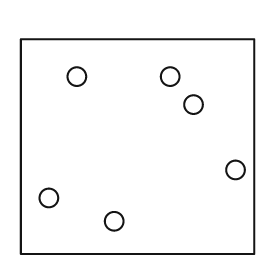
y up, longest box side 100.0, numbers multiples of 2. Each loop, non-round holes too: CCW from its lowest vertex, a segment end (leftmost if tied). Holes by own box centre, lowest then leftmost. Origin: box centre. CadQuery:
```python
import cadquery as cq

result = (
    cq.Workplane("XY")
    .moveTo(-50.0, -46.0)
    .lineTo(50.0, -46.0)
    .lineTo(50.0, 46.0)
    .lineTo(-50.0, 46.0)
    .close()
    .moveTo(-10.0, -32.0)
    .circle(4.0)
    .moveTo(-38.0, -22.0)
    .circle(4.0)
    .moveTo(42.0, -10.0)
    .circle(4.0)
    .moveTo(24.0, 18.0)
    .circle(4.0)
    .moveTo(-26.0, 30.0)
    .circle(4.0)
    .moveTo(14.0, 30.0)
    .circle(4.0)
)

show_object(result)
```